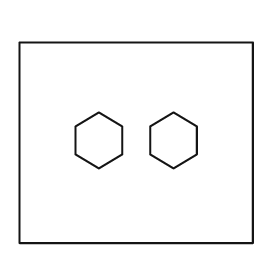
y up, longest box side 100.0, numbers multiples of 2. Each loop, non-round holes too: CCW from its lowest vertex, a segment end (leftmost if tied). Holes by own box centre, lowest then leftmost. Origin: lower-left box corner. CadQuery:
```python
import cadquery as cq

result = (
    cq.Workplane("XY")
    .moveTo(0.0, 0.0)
    .lineTo(100.0, 0.0)
    .lineTo(100.0, 86.0)
    .lineTo(0.0, 86.0)
    .close()
    .moveTo(34.0, 32.0)
    .lineTo(44.0, 38.0)
    .lineTo(44.0, 50.0)
    .lineTo(34.0, 56.0)
    .lineTo(24.0, 50.0)
    .lineTo(24.0, 38.0)
    .close()
    .moveTo(66.0, 32.0)
    .lineTo(76.0, 38.0)
    .lineTo(76.0, 50.0)
    .lineTo(66.0, 56.0)
    .lineTo(56.0, 50.0)
    .lineTo(56.0, 38.0)
    .close()
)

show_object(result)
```